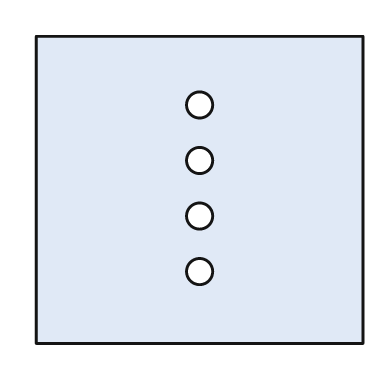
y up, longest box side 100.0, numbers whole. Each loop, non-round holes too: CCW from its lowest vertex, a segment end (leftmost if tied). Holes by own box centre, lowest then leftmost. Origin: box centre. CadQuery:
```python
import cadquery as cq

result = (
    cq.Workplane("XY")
    .moveTo(-50.0, -47.0)
    .lineTo(50.0, -47.0)
    .lineTo(50.0, 47.0)
    .lineTo(-50.0, 47.0)
    .close()
    .moveTo(0.0, -25.0)
    .circle(4.0)
    .moveTo(0.0, -8.0)
    .circle(4.0)
    .moveTo(0.0, 9.0)
    .circle(4.0)
    .moveTo(0.0, 26.0)
    .circle(4.0)
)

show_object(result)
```